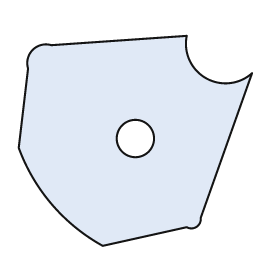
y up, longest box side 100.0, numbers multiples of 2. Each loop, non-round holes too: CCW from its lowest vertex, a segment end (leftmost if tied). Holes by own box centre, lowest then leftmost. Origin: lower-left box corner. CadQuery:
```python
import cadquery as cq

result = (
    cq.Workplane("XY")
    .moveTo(36.0, 0.0)
    .lineTo(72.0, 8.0)
    .threePointArc((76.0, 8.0), (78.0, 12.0))
    .lineTo(100.0, 74.0)
    .threePointArc((80.0, 72.0), (72.0, 90.0))
    .lineTo(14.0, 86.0)
    .threePointArc((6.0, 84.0), (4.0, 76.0))
    .lineTo(0.0, 42.0)
    .threePointArc((14.0, 18.0), (36.0, 0.0))
    .close()
    .moveTo(50.0, 46.0)
    .circle(8.0)
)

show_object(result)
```